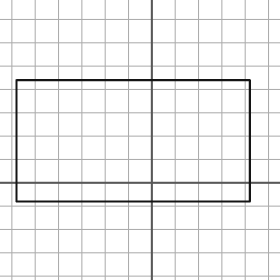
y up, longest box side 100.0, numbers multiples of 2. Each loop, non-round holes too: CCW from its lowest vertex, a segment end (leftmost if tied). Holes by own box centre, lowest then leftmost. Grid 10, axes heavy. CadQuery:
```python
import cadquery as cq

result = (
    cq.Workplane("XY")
    .moveTo(-58.0, -8.0)
    .lineTo(42.0, -8.0)
    .lineTo(42.0, 44.0)
    .lineTo(-58.0, 44.0)
    .close()
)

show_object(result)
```